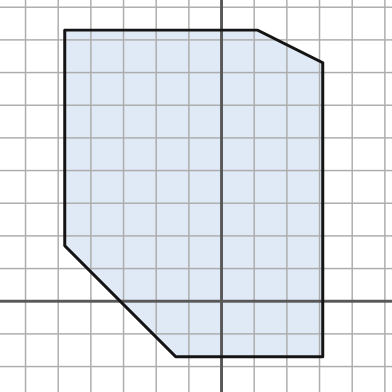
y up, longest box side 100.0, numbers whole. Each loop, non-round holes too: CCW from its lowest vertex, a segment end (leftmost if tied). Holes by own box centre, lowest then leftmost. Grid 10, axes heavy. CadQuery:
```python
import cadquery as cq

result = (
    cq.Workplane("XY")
    .moveTo(-14.0, -17.0)
    .lineTo(31.0, -17.0)
    .lineTo(31.0, 73.0)
    .lineTo(11.0, 83.0)
    .lineTo(-48.0, 83.0)
    .lineTo(-48.0, 17.0)
    .close()
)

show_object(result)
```